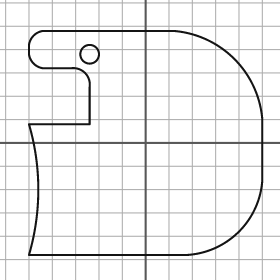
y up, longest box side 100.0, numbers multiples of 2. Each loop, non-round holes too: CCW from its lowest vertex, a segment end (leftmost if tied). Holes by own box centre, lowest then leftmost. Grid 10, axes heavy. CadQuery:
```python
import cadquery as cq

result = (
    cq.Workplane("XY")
    .moveTo(-50.0, -48.0)
    .lineTo(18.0, -48.0)
    .threePointArc((40.0, -38.0), (50.0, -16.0))
    .lineTo(50.0, 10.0)
    .threePointArc((38.0, 36.0), (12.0, 48.0))
    .lineTo(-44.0, 48.0)
    .threePointArc((-48.0, 46.0), (-50.0, 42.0))
    .lineTo(-50.0, 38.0)
    .threePointArc((-48.0, 34.0), (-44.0, 32.0))
    .lineTo(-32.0, 32.0)
    .threePointArc((-26.0, 30.0), (-24.0, 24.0))
    .lineTo(-24.0, 8.0)
    .lineTo(-50.0, 8.0)
    .threePointArc((-46.0, -20.0), (-50.0, -48.0))
    .close()
    .moveTo(-24.0, 38.0)
    .circle(4.0)
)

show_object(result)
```